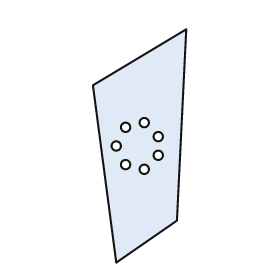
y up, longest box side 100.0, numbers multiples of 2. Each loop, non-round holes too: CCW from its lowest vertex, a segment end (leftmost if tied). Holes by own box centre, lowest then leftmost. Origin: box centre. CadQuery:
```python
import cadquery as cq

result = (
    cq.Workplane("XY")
    .moveTo(-10.0, -50.0)
    .lineTo(16.0, -32.0)
    .lineTo(20.0, 50.0)
    .lineTo(-20.0, 26.0)
    .close()
    .moveTo(2.0, -10.0)
    .circle(2.0)
    .moveTo(-6.0, -8.0)
    .circle(2.0)
    .moveTo(8.0, -4.0)
    .circle(2.0)
    .moveTo(-10.0, 0.0)
    .circle(2.0)
    .moveTo(8.0, 4.0)
    .circle(2.0)
    .moveTo(-6.0, 8.0)
    .circle(2.0)
    .moveTo(2.0, 10.0)
    .circle(2.0)
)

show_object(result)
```